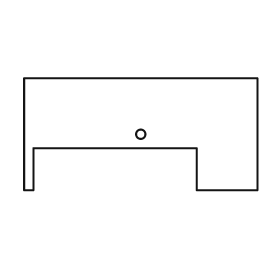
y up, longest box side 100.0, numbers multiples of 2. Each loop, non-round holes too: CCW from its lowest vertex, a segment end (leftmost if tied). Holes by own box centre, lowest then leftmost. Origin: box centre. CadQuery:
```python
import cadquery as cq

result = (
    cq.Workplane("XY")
    .moveTo(-50.0, -24.0)
    .lineTo(-46.0, -24.0)
    .lineTo(-46.0, -6.0)
    .lineTo(24.0, -6.0)
    .lineTo(24.0, -24.0)
    .lineTo(50.0, -24.0)
    .lineTo(50.0, 24.0)
    .lineTo(-50.0, 24.0)
    .close()
    .moveTo(0.0, 0.0)
    .circle(2.0)
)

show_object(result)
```